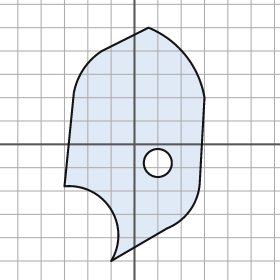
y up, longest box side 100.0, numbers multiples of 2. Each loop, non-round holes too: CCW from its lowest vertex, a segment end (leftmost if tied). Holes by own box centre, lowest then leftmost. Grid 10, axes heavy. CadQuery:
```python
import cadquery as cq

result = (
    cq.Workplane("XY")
    .moveTo(-10.0, -50.0)
    .lineTo(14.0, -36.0)
    .threePointArc((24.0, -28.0), (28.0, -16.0))
    .lineTo(30.0, 20.0)
    .threePointArc((22.0, 38.0), (6.0, 50.0))
    .lineTo(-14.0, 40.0)
    .threePointArc((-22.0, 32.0), (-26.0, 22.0))
    .lineTo(-30.0, -18.0)
    .threePointArc((-10.0, -28.0), (-10.0, -50.0))
    .close()
    .moveTo(10.0, -8.0)
    .circle(6.0)
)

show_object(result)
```